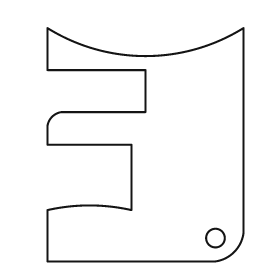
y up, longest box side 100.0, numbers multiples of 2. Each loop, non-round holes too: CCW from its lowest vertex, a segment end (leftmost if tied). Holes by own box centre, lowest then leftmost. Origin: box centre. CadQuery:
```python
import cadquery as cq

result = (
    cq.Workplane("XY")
    .moveTo(-42.0, -50.0)
    .lineTo(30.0, -50.0)
    .threePointArc((38.0, -46.0), (42.0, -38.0))
    .lineTo(42.0, 50.0)
    .threePointArc((0.0, 38.0), (-42.0, 50.0))
    .lineTo(-42.0, 32.0)
    .lineTo(0.0, 32.0)
    .lineTo(0.0, 14.0)
    .lineTo(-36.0, 14.0)
    .threePointArc((-40.0, 12.0), (-42.0, 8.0))
    .lineTo(-42.0, 0.0)
    .lineTo(-6.0, 0.0)
    .lineTo(-6.0, -28.0)
    .threePointArc((-24.0, -26.0), (-42.0, -28.0))
    .close()
    .moveTo(30.0, -40.0)
    .circle(4.0)
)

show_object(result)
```